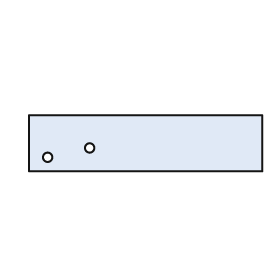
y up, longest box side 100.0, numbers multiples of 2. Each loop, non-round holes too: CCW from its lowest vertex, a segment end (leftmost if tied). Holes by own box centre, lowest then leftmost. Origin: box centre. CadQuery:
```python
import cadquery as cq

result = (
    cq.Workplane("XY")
    .moveTo(-50.0, -12.0)
    .lineTo(50.0, -12.0)
    .lineTo(50.0, 12.0)
    .lineTo(-50.0, 12.0)
    .close()
    .moveTo(-42.0, -6.0)
    .circle(2.0)
    .moveTo(-24.0, -2.0)
    .circle(2.0)
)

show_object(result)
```